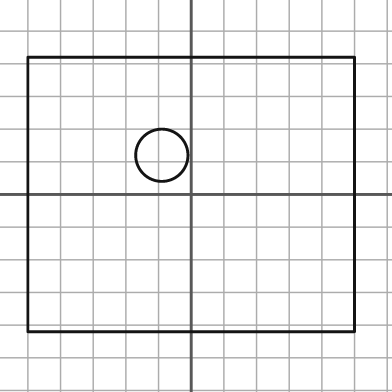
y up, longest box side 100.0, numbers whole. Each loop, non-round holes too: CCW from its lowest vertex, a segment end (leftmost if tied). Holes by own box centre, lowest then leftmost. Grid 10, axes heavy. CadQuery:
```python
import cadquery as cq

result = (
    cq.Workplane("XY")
    .moveTo(-50.0, -42.0)
    .lineTo(50.0, -42.0)
    .lineTo(50.0, 42.0)
    .lineTo(-50.0, 42.0)
    .close()
    .moveTo(-9.0, 12.0)
    .circle(8.0)
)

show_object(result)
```